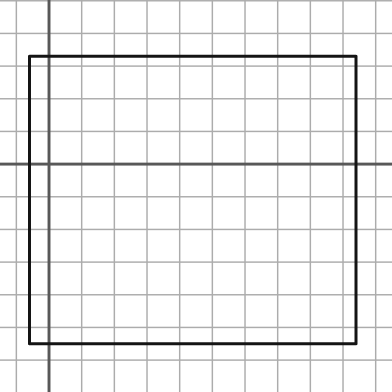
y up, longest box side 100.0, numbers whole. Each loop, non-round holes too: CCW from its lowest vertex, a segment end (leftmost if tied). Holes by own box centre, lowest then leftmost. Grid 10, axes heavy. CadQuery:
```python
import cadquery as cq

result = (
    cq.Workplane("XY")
    .moveTo(-6.0, -55.0)
    .lineTo(94.0, -55.0)
    .lineTo(94.0, 33.0)
    .lineTo(-6.0, 33.0)
    .close()
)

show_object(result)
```